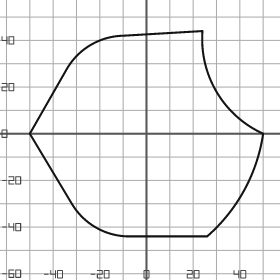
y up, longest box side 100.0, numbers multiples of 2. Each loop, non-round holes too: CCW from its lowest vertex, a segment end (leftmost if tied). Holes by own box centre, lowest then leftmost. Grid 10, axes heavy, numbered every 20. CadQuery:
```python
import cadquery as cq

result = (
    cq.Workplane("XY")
    .moveTo(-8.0, -44.0)
    .lineTo(26.0, -44.0)
    .threePointArc((42.0, -24.0), (50.0, 0.0))
    .threePointArc((30.0, 18.0), (24.0, 44.0))
    .lineTo(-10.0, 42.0)
    .threePointArc((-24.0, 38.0), (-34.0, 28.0))
    .lineTo(-50.0, 0.0)
    .lineTo(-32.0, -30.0)
    .threePointArc((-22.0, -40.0), (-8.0, -44.0))
    .close()
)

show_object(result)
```